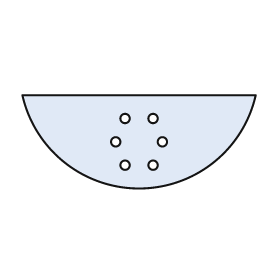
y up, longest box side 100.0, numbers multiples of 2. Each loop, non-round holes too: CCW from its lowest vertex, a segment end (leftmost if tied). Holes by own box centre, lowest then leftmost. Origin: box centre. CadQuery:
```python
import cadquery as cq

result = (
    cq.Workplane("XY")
    .moveTo(-50.0, 20.0)
    .threePointArc((0.0, -20.0), (50.0, 20.0))
    .close()
    .moveTo(-6.0, -10.0)
    .circle(2.0)
    .moveTo(6.0, -10.0)
    .circle(2.0)
    .moveTo(-10.0, 0.0)
    .circle(2.0)
    .moveTo(10.0, 0.0)
    .circle(2.0)
    .moveTo(-6.0, 10.0)
    .circle(2.0)
    .moveTo(6.0, 10.0)
    .circle(2.0)
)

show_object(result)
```